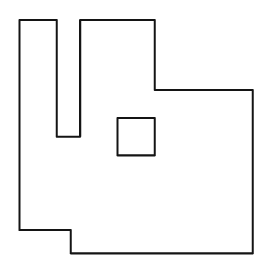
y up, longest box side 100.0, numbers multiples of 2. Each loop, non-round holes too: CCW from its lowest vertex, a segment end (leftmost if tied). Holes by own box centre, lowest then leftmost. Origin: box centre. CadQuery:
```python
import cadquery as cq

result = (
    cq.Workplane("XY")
    .moveTo(-28.0, -50.0)
    .lineTo(50.0, -50.0)
    .lineTo(50.0, 20.0)
    .lineTo(8.0, 20.0)
    .lineTo(8.0, 50.0)
    .lineTo(-24.0, 50.0)
    .lineTo(-24.0, 0.0)
    .lineTo(-34.0, 0.0)
    .lineTo(-34.0, 50.0)
    .lineTo(-50.0, 50.0)
    .lineTo(-50.0, -40.0)
    .lineTo(-28.0, -40.0)
    .close()
    .moveTo(-8.0, -8.0)
    .lineTo(8.0, -8.0)
    .lineTo(8.0, 8.0)
    .lineTo(-8.0, 8.0)
    .close()
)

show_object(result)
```